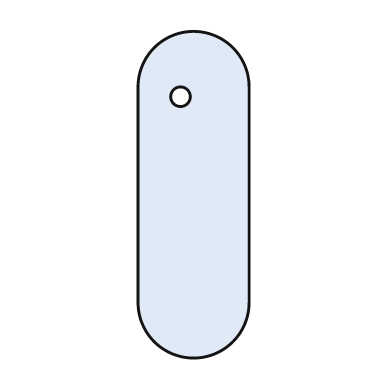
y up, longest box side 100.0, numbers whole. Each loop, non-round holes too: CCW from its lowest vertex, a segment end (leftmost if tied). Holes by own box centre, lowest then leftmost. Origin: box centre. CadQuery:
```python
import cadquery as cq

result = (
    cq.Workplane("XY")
    .moveTo(-17.0, -33.0)
    .threePointArc((0.0, -50.0), (17.0, -33.0))
    .lineTo(17.0, 33.0)
    .threePointArc((0.0, 50.0), (-17.0, 33.0))
    .close()
    .moveTo(-4.0, 30.0)
    .circle(3.0)
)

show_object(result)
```